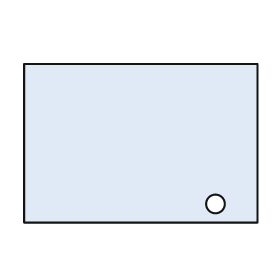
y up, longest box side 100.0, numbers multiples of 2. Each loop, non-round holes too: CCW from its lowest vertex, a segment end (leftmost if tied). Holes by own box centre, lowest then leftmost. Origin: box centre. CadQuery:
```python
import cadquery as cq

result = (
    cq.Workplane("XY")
    .moveTo(-50.0, -34.0)
    .lineTo(50.0, -34.0)
    .lineTo(50.0, 34.0)
    .lineTo(-50.0, 34.0)
    .close()
    .moveTo(32.0, -26.0)
    .circle(4.0)
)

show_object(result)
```